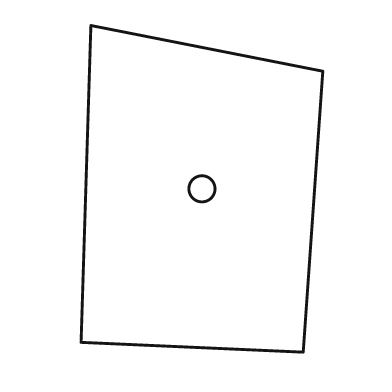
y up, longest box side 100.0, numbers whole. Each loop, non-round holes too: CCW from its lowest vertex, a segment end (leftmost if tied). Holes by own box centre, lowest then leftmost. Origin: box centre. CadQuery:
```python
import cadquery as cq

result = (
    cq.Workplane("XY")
    .moveTo(31.0, -50.0)
    .lineTo(37.0, 36.0)
    .lineTo(-34.0, 50.0)
    .lineTo(-37.0, -47.0)
    .close()
    .moveTo(0.0, 0.0)
    .circle(4.0)
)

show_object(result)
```